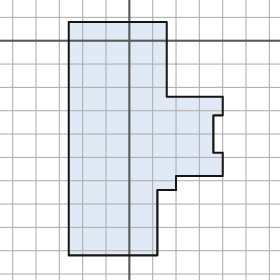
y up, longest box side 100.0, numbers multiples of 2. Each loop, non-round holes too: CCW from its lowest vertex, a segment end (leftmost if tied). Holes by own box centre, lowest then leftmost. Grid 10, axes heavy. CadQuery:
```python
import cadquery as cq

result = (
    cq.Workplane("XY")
    .moveTo(-26.0, -92.0)
    .lineTo(12.0, -92.0)
    .lineTo(12.0, -64.0)
    .lineTo(20.0, -64.0)
    .lineTo(20.0, -58.0)
    .lineTo(40.0, -58.0)
    .lineTo(40.0, -48.0)
    .lineTo(36.0, -48.0)
    .lineTo(36.0, -32.0)
    .lineTo(40.0, -32.0)
    .lineTo(40.0, -24.0)
    .lineTo(16.0, -24.0)
    .lineTo(16.0, 8.0)
    .lineTo(-26.0, 8.0)
    .close()
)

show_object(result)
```